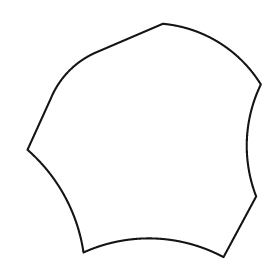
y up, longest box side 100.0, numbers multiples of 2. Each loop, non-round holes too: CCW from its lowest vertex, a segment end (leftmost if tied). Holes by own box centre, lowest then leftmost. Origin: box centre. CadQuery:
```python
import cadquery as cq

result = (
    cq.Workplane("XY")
    .moveTo(34.0, -50.0)
    .lineTo(48.0, -24.0)
    .threePointArc((44.0, 0.0), (50.0, 24.0))
    .threePointArc((32.0, 42.0), (8.0, 50.0))
    .lineTo(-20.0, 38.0)
    .threePointArc((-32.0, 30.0), (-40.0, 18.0))
    .lineTo(-50.0, -4.0)
    .threePointArc((-34.0, -24.0), (-26.0, -48.0))
    .threePointArc((4.0, -42.0), (34.0, -50.0))
    .close()
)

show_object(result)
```